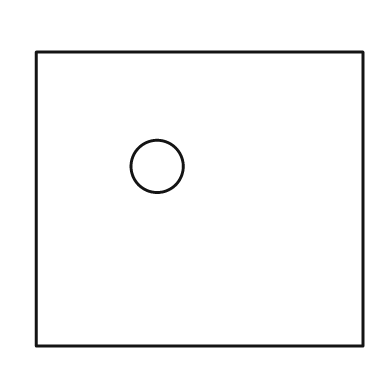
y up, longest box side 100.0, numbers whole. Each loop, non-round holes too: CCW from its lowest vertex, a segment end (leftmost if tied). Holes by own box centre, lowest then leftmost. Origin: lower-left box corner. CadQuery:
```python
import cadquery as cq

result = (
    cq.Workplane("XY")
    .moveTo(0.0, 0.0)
    .lineTo(100.0, 0.0)
    .lineTo(100.0, 90.0)
    .lineTo(0.0, 90.0)
    .close()
    .moveTo(37.0, 55.0)
    .circle(8.0)
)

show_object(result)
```